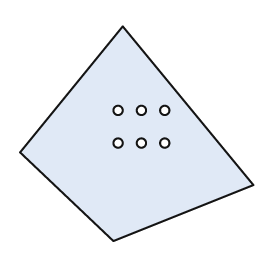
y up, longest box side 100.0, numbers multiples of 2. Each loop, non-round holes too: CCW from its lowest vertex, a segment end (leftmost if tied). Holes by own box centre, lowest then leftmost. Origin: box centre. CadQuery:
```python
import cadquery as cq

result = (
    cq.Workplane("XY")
    .moveTo(-10.0, -46.0)
    .lineTo(50.0, -22.0)
    .lineTo(-6.0, 46.0)
    .lineTo(-50.0, -8.0)
    .close()
    .moveTo(-8.0, -4.0)
    .circle(2.0)
    .moveTo(2.0, -4.0)
    .circle(2.0)
    .moveTo(12.0, -4.0)
    .circle(2.0)
    .moveTo(-8.0, 10.0)
    .circle(2.0)
    .moveTo(2.0, 10.0)
    .circle(2.0)
    .moveTo(12.0, 10.0)
    .circle(2.0)
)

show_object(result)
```